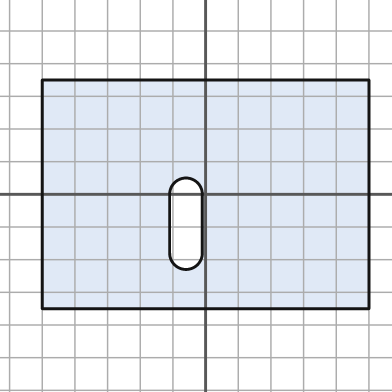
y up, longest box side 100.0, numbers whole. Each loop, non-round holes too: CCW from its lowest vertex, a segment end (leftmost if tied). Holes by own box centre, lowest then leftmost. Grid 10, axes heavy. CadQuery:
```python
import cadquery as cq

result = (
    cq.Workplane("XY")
    .moveTo(-50.0, -35.0)
    .lineTo(50.0, -35.0)
    .lineTo(50.0, 35.0)
    .lineTo(-50.0, 35.0)
    .close()
    .moveTo(-11.0, -18.0)
    .threePointArc((-6.0, -23.0), (-1.0, -18.0))
    .lineTo(-1.0, 0.0)
    .threePointArc((-6.0, 5.0), (-11.0, 0.0))
    .close()
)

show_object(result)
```